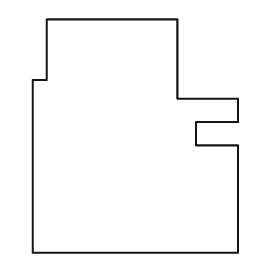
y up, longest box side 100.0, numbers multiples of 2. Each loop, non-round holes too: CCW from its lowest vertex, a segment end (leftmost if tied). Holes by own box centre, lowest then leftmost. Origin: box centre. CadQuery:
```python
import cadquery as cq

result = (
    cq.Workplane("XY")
    .moveTo(-44.0, -50.0)
    .lineTo(44.0, -50.0)
    .lineTo(44.0, -4.0)
    .lineTo(26.0, -4.0)
    .lineTo(26.0, 6.0)
    .lineTo(44.0, 6.0)
    .lineTo(44.0, 16.0)
    .lineTo(18.0, 16.0)
    .lineTo(18.0, 50.0)
    .lineTo(-38.0, 50.0)
    .lineTo(-38.0, 24.0)
    .lineTo(-44.0, 24.0)
    .close()
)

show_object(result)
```